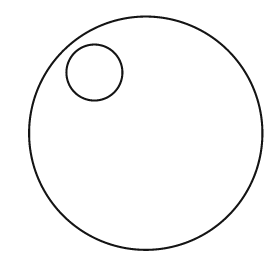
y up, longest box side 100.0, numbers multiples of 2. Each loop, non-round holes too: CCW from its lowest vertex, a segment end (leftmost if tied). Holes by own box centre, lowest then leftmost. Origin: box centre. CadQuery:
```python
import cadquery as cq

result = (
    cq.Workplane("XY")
    .moveTo(0.0, 0.0)
    .circle(50.0)
    .moveTo(-22.0, 26.0)
    .circle(12.0)
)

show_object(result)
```